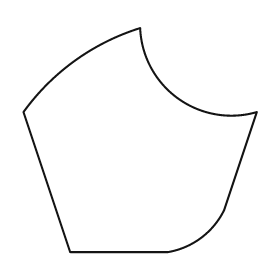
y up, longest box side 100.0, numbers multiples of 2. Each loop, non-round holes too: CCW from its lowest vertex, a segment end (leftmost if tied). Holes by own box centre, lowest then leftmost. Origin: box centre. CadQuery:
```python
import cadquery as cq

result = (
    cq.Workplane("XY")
    .moveTo(-30.0, -48.0)
    .lineTo(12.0, -48.0)
    .threePointArc((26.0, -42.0), (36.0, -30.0))
    .lineTo(50.0, 12.0)
    .threePointArc((16.0, 18.0), (0.0, 48.0))
    .threePointArc((-28.0, 34.0), (-50.0, 12.0))
    .close()
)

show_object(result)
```